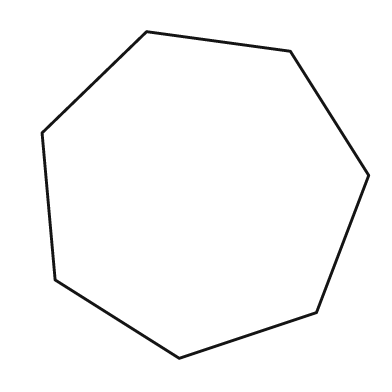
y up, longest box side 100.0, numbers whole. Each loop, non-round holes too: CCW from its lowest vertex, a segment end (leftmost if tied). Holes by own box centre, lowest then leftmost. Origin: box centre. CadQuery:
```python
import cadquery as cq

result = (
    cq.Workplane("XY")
    .moveTo(-8.0, -50.0)
    .lineTo(34.0, -36.0)
    .lineTo(50.0, 6.0)
    .lineTo(26.0, 44.0)
    .lineTo(-18.0, 50.0)
    .lineTo(-50.0, 19.0)
    .lineTo(-46.0, -26.0)
    .close()
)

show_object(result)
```